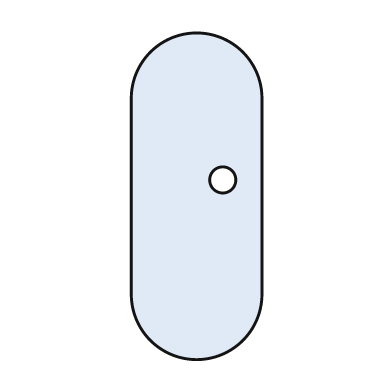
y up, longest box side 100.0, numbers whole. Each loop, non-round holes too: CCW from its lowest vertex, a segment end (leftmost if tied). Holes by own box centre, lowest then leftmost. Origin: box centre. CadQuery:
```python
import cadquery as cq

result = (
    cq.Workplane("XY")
    .moveTo(-20.0, -30.0)
    .threePointArc((0.0, -50.0), (20.0, -30.0))
    .lineTo(20.0, 30.0)
    .threePointArc((0.0, 50.0), (-20.0, 30.0))
    .close()
    .moveTo(8.0, 5.0)
    .circle(4.0)
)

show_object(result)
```